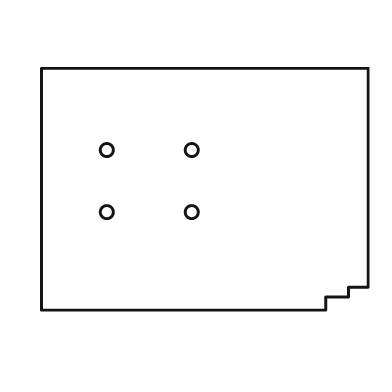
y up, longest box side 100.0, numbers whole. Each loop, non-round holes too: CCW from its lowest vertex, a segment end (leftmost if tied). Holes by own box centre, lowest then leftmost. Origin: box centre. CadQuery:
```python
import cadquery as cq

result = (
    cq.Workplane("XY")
    .moveTo(-50.0, -37.0)
    .lineTo(37.0, -37.0)
    .lineTo(37.0, -33.0)
    .lineTo(44.0, -33.0)
    .lineTo(44.0, -30.0)
    .lineTo(50.0, -30.0)
    .lineTo(50.0, 37.0)
    .lineTo(-50.0, 37.0)
    .close()
    .moveTo(-30.0, -7.0)
    .circle(2.0)
    .moveTo(-4.0, -7.0)
    .circle(2.0)
    .moveTo(-30.0, 12.0)
    .circle(2.0)
    .moveTo(-4.0, 12.0)
    .circle(2.0)
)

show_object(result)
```